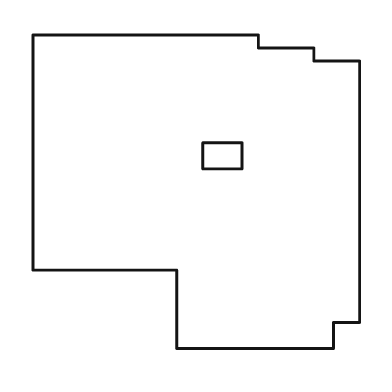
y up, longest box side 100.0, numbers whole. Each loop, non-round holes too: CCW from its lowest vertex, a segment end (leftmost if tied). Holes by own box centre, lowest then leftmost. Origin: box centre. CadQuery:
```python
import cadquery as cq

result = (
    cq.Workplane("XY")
    .moveTo(-6.0, -48.0)
    .lineTo(42.0, -48.0)
    .lineTo(42.0, -40.0)
    .lineTo(50.0, -40.0)
    .lineTo(50.0, 40.0)
    .lineTo(36.0, 40.0)
    .lineTo(36.0, 44.0)
    .lineTo(19.0, 44.0)
    .lineTo(19.0, 48.0)
    .lineTo(-50.0, 48.0)
    .lineTo(-50.0, -24.0)
    .lineTo(-6.0, -24.0)
    .close()
    .moveTo(2.0, 7.0)
    .lineTo(14.0, 7.0)
    .lineTo(14.0, 15.0)
    .lineTo(2.0, 15.0)
    .close()
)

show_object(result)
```